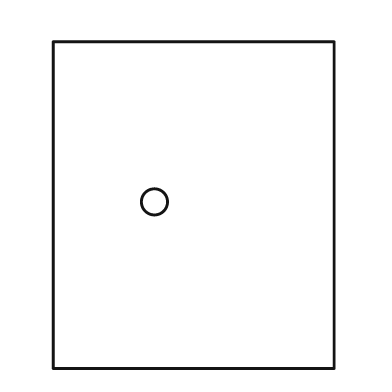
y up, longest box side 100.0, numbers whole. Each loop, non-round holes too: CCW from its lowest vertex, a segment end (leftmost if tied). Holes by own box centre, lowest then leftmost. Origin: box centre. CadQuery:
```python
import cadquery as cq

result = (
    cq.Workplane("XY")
    .moveTo(-43.0, -50.0)
    .lineTo(43.0, -50.0)
    .lineTo(43.0, 50.0)
    .lineTo(-43.0, 50.0)
    .close()
    .moveTo(-12.0, 1.0)
    .circle(4.0)
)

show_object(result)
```